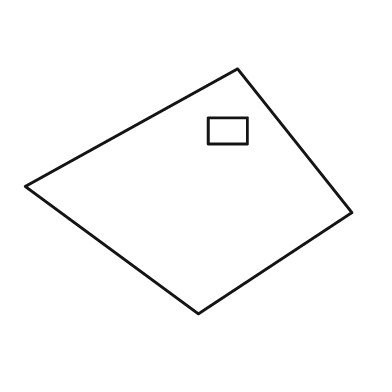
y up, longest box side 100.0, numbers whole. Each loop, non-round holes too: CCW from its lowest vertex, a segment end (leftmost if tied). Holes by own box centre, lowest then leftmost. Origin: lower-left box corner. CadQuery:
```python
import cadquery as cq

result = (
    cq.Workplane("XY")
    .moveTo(53.0, 0.0)
    .lineTo(100.0, 31.0)
    .lineTo(65.0, 75.0)
    .lineTo(0.0, 39.0)
    .close()
    .moveTo(56.0, 52.0)
    .lineTo(68.0, 52.0)
    .lineTo(68.0, 60.0)
    .lineTo(56.0, 60.0)
    .close()
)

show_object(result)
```